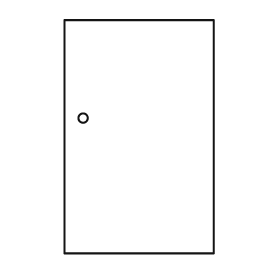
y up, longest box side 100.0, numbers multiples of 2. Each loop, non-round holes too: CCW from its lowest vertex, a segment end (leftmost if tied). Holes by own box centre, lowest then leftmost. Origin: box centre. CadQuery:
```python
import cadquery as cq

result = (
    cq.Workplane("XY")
    .moveTo(-32.0, -50.0)
    .lineTo(32.0, -50.0)
    .lineTo(32.0, 50.0)
    .lineTo(-32.0, 50.0)
    .close()
    .moveTo(-24.0, 8.0)
    .circle(2.0)
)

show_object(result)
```